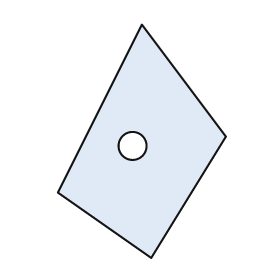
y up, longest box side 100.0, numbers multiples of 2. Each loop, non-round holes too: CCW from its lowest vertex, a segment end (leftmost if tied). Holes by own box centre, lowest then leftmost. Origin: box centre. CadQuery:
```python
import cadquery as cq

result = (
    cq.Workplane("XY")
    .moveTo(4.0, -50.0)
    .lineTo(36.0, 2.0)
    .lineTo(0.0, 50.0)
    .lineTo(-36.0, -22.0)
    .close()
    .moveTo(-4.0, -2.0)
    .circle(6.0)
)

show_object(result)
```